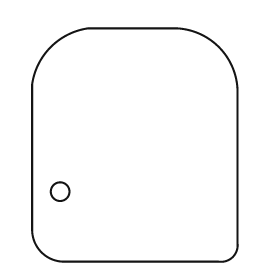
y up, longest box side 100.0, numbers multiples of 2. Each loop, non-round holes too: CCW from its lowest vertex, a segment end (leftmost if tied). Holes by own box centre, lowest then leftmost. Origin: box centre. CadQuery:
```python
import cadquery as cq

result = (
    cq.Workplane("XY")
    .moveTo(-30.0, -50.0)
    .lineTo(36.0, -50.0)
    .threePointArc((42.0, -48.0), (44.0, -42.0))
    .lineTo(44.0, 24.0)
    .threePointArc((36.0, 42.0), (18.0, 50.0))
    .lineTo(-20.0, 50.0)
    .threePointArc((-36.0, 42.0), (-44.0, 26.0))
    .lineTo(-44.0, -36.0)
    .threePointArc((-40.0, -46.0), (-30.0, -50.0))
    .close()
    .moveTo(-32.0, -20.0)
    .circle(4.0)
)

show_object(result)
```